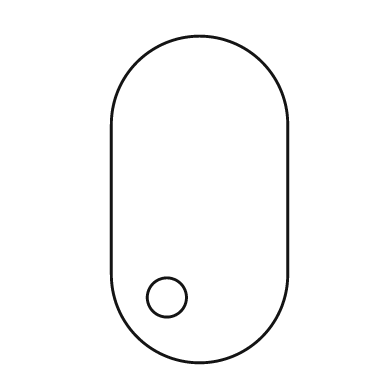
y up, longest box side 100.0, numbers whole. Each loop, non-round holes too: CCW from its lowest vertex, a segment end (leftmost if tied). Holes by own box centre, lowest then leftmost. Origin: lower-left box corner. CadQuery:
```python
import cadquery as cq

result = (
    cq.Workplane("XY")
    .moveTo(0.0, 27.0)
    .threePointArc((27.0, 0.0), (54.0, 27.0))
    .lineTo(54.0, 73.0)
    .threePointArc((27.0, 100.0), (0.0, 73.0))
    .close()
    .moveTo(17.0, 20.0)
    .circle(6.0)
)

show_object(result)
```